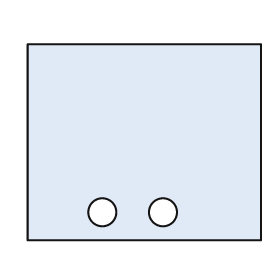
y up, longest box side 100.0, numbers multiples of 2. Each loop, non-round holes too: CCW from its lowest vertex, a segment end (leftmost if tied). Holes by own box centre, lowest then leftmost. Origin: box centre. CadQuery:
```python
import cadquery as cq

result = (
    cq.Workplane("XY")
    .moveTo(-50.0, -42.0)
    .lineTo(50.0, -42.0)
    .lineTo(50.0, 42.0)
    .lineTo(-50.0, 42.0)
    .close()
    .moveTo(-18.0, -30.0)
    .circle(6.0)
    .moveTo(8.0, -30.0)
    .circle(6.0)
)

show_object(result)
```